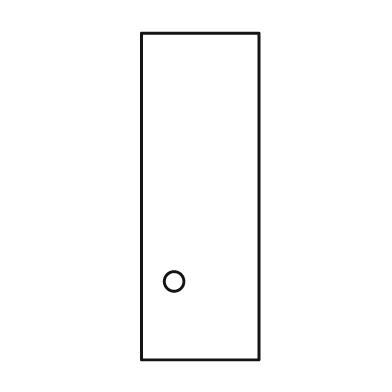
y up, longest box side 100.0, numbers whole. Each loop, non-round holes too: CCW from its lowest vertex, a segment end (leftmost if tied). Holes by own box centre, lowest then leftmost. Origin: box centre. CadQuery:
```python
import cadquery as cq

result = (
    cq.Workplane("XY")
    .moveTo(-18.0, -50.0)
    .lineTo(18.0, -50.0)
    .lineTo(18.0, 50.0)
    .lineTo(-18.0, 50.0)
    .close()
    .moveTo(-8.0, -26.0)
    .circle(3.0)
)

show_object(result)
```